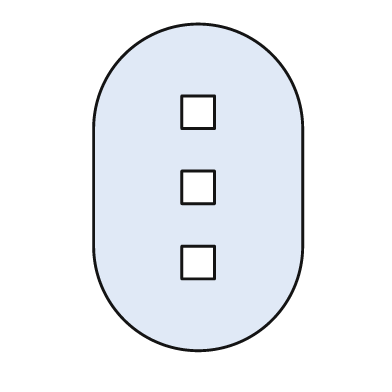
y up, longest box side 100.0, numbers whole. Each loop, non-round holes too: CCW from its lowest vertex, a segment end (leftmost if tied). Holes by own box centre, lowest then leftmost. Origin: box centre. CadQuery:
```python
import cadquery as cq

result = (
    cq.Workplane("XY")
    .moveTo(-32.0, -18.0)
    .threePointArc((0.0, -50.0), (32.0, -18.0))
    .lineTo(32.0, 18.0)
    .threePointArc((0.0, 50.0), (-32.0, 18.0))
    .close()
    .moveTo(-5.0, -28.0)
    .lineTo(5.0, -28.0)
    .lineTo(5.0, -18.0)
    .lineTo(-5.0, -18.0)
    .close()
    .moveTo(-5.0, -5.0)
    .lineTo(5.0, -5.0)
    .lineTo(5.0, 5.0)
    .lineTo(-5.0, 5.0)
    .close()
    .moveTo(-5.0, 18.0)
    .lineTo(5.0, 18.0)
    .lineTo(5.0, 28.0)
    .lineTo(-5.0, 28.0)
    .close()
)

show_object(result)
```